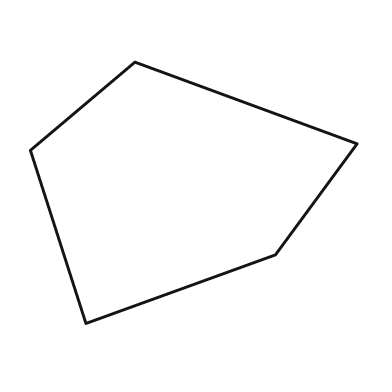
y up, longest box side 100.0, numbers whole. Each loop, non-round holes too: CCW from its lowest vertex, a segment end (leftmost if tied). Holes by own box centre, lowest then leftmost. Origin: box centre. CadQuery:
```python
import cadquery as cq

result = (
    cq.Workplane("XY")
    .moveTo(-33.0, -40.0)
    .lineTo(25.0, -19.0)
    .lineTo(50.0, 15.0)
    .lineTo(-18.0, 40.0)
    .lineTo(-50.0, 13.0)
    .close()
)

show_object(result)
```